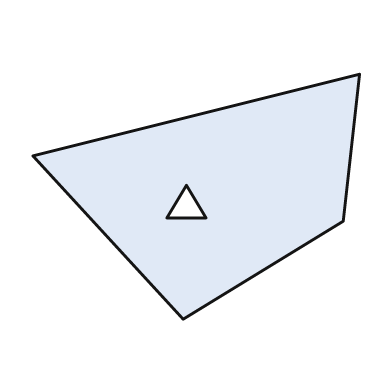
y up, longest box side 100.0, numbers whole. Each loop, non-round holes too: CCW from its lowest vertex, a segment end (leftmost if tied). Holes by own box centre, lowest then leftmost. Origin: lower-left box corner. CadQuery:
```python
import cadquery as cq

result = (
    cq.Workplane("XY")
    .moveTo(46.0, 0.0)
    .lineTo(95.0, 30.0)
    .lineTo(100.0, 75.0)
    .lineTo(0.0, 50.0)
    .close()
    .moveTo(41.0, 31.0)
    .lineTo(53.0, 31.0)
    .lineTo(47.0, 41.0)
    .close()
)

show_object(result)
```